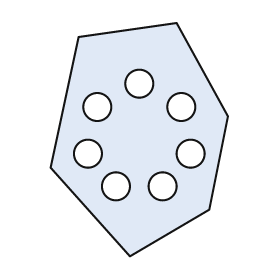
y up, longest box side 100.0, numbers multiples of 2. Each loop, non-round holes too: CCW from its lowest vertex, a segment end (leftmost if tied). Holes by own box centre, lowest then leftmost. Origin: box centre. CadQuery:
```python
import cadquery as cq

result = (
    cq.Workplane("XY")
    .moveTo(-4.0, -50.0)
    .lineTo(30.0, -30.0)
    .lineTo(38.0, 10.0)
    .lineTo(16.0, 50.0)
    .lineTo(-26.0, 44.0)
    .lineTo(-38.0, -12.0)
    .close()
    .moveTo(-10.0, -20.0)
    .circle(6.0)
    .moveTo(10.0, -20.0)
    .circle(6.0)
    .moveTo(-22.0, -6.0)
    .circle(6.0)
    .moveTo(22.0, -6.0)
    .circle(6.0)
    .moveTo(-18.0, 14.0)
    .circle(6.0)
    .moveTo(18.0, 14.0)
    .circle(6.0)
    .moveTo(0.0, 24.0)
    .circle(6.0)
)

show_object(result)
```